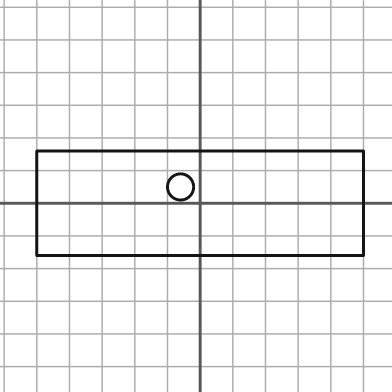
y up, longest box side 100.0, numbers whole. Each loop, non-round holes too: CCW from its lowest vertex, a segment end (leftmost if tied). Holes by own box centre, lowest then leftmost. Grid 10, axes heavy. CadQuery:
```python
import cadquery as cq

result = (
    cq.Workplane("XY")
    .moveTo(-50.0, -16.0)
    .lineTo(50.0, -16.0)
    .lineTo(50.0, 16.0)
    .lineTo(-50.0, 16.0)
    .close()
    .moveTo(-6.0, 5.0)
    .circle(4.0)
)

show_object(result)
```